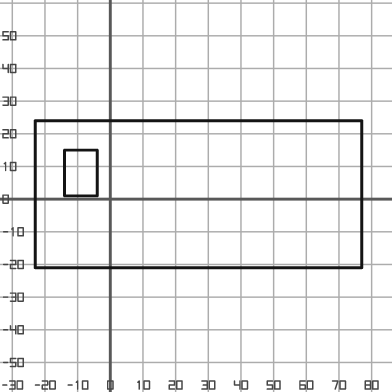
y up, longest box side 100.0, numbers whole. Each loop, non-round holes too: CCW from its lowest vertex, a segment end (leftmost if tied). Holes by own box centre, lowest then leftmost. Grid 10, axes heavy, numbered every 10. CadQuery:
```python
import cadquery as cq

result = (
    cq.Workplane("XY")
    .moveTo(-23.0, -21.0)
    .lineTo(77.0, -21.0)
    .lineTo(77.0, 24.0)
    .lineTo(-23.0, 24.0)
    .close()
    .moveTo(-14.0, 1.0)
    .lineTo(-4.0, 1.0)
    .lineTo(-4.0, 15.0)
    .lineTo(-14.0, 15.0)
    .close()
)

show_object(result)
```